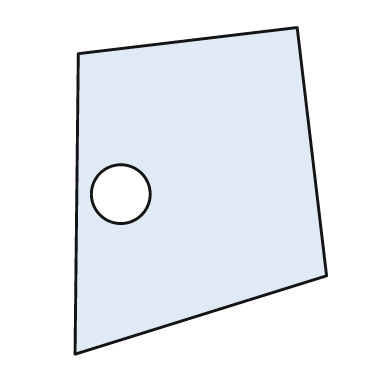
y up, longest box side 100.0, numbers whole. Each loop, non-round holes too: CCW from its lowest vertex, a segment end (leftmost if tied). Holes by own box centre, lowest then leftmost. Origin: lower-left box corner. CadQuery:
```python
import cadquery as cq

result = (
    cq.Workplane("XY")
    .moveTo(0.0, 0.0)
    .lineTo(77.0, 24.0)
    .lineTo(68.0, 100.0)
    .lineTo(1.0, 92.0)
    .close()
    .moveTo(14.0, 49.0)
    .circle(9.0)
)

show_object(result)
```